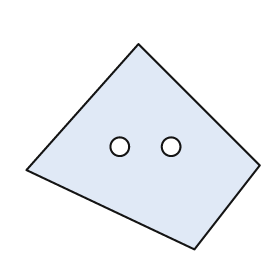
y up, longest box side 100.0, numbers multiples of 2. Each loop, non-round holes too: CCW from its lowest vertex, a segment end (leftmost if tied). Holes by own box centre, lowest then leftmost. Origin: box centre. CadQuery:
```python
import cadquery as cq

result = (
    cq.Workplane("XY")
    .moveTo(22.0, -44.0)
    .lineTo(50.0, -8.0)
    .lineTo(-2.0, 44.0)
    .lineTo(-50.0, -10.0)
    .close()
    .moveTo(-10.0, 0.0)
    .circle(4.0)
    .moveTo(12.0, 0.0)
    .circle(4.0)
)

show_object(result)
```